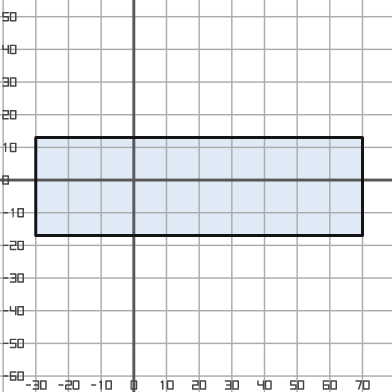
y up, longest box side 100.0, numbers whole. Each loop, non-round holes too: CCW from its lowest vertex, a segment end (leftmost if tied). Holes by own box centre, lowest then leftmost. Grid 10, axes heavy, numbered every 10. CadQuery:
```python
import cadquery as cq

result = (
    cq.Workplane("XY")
    .moveTo(-30.0, -17.0)
    .lineTo(70.0, -17.0)
    .lineTo(70.0, 13.0)
    .lineTo(-30.0, 13.0)
    .close()
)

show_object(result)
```